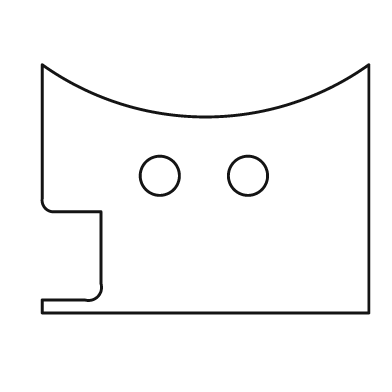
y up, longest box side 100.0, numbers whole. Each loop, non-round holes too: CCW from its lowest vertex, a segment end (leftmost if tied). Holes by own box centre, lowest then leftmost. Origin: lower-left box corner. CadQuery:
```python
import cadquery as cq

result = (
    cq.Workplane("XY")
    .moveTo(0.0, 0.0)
    .lineTo(100.0, 0.0)
    .lineTo(100.0, 76.0)
    .threePointArc((50.0, 60.0), (0.0, 76.0))
    .lineTo(0.0, 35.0)
    .threePointArc((1.0, 32.0), (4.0, 31.0))
    .lineTo(18.0, 31.0)
    .lineTo(18.0, 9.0)
    .threePointArc((17.0, 5.0), (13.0, 4.0))
    .lineTo(0.0, 4.0)
    .close()
    .moveTo(36.0, 42.0)
    .circle(6.0)
    .moveTo(63.0, 42.0)
    .circle(6.0)
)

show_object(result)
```